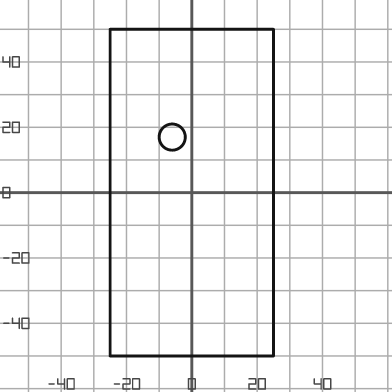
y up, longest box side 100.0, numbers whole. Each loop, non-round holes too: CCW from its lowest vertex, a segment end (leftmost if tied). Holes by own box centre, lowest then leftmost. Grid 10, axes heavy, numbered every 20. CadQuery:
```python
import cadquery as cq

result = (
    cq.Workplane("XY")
    .moveTo(-25.0, -50.0)
    .lineTo(25.0, -50.0)
    .lineTo(25.0, 50.0)
    .lineTo(-25.0, 50.0)
    .close()
    .moveTo(-6.0, 17.0)
    .circle(4.0)
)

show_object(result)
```